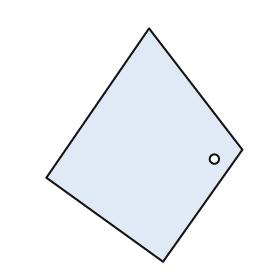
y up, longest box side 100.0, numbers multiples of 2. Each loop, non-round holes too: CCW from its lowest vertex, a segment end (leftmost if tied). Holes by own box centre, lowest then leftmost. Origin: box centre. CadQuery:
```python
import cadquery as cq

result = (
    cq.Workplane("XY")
    .moveTo(8.0, -50.0)
    .lineTo(42.0, -2.0)
    .lineTo(2.0, 50.0)
    .lineTo(-42.0, -14.0)
    .close()
    .moveTo(30.0, -6.0)
    .circle(2.0)
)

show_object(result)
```